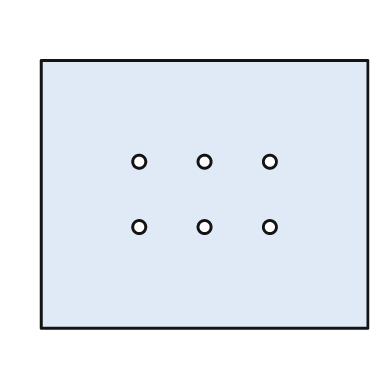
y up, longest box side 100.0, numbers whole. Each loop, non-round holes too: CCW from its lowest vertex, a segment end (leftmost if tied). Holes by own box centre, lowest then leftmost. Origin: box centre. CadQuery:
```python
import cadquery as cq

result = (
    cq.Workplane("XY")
    .moveTo(-50.0, -41.0)
    .lineTo(50.0, -41.0)
    .lineTo(50.0, 41.0)
    .lineTo(-50.0, 41.0)
    .close()
    .moveTo(-20.0, -10.0)
    .circle(2.0)
    .moveTo(0.0, -10.0)
    .circle(2.0)
    .moveTo(20.0, -10.0)
    .circle(2.0)
    .moveTo(-20.0, 10.0)
    .circle(2.0)
    .moveTo(0.0, 10.0)
    .circle(2.0)
    .moveTo(20.0, 10.0)
    .circle(2.0)
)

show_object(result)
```